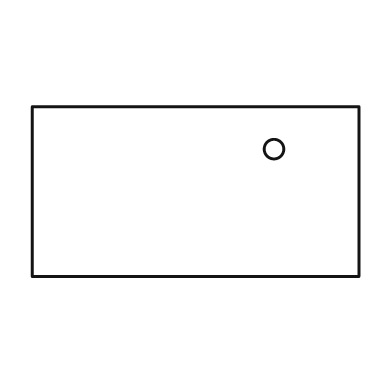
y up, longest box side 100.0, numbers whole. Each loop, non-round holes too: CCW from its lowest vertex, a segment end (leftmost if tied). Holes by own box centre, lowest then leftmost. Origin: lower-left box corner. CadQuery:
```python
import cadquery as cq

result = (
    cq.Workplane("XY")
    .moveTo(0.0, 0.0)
    .lineTo(100.0, 0.0)
    .lineTo(100.0, 52.0)
    .lineTo(0.0, 52.0)
    .close()
    .moveTo(74.0, 39.0)
    .circle(3.0)
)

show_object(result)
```